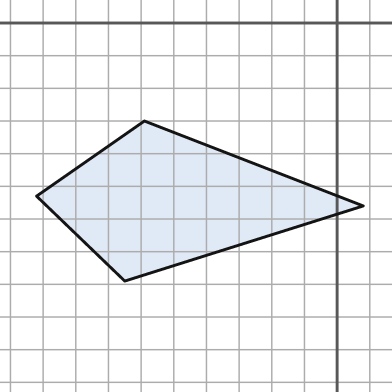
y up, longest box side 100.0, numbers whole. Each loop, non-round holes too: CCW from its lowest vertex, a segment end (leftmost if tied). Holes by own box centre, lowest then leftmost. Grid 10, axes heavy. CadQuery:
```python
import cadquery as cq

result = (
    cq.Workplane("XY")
    .moveTo(-65.0, -79.0)
    .lineTo(8.0, -56.0)
    .lineTo(-59.0, -30.0)
    .lineTo(-92.0, -53.0)
    .close()
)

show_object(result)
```